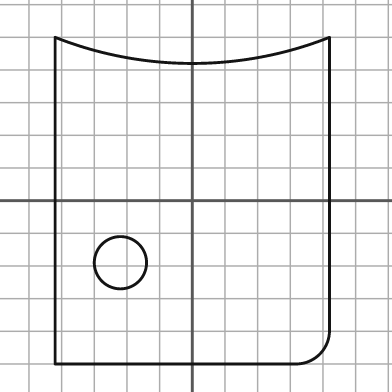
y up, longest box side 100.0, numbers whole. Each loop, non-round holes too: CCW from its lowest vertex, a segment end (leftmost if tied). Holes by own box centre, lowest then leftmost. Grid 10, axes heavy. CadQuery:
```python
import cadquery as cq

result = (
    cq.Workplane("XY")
    .moveTo(-42.0, -50.0)
    .lineTo(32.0, -50.0)
    .threePointArc((39.0, -47.0), (42.0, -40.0))
    .lineTo(42.0, 50.0)
    .threePointArc((0.0, 42.0), (-42.0, 50.0))
    .close()
    .moveTo(-22.0, -19.0)
    .circle(8.0)
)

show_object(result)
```